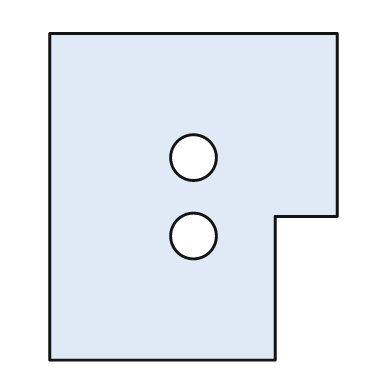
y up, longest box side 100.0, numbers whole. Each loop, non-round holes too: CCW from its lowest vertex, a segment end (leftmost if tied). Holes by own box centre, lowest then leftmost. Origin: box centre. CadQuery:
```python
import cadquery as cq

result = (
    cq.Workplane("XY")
    .moveTo(-44.0, -50.0)
    .lineTo(25.0, -50.0)
    .lineTo(25.0, -6.0)
    .lineTo(44.0, -6.0)
    .lineTo(44.0, 50.0)
    .lineTo(-44.0, 50.0)
    .close()
    .moveTo(0.0, -12.0)
    .circle(7.0)
    .moveTo(0.0, 12.0)
    .circle(7.0)
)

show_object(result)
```